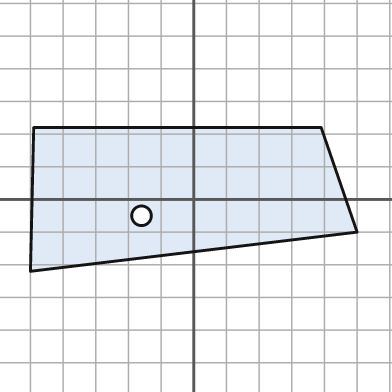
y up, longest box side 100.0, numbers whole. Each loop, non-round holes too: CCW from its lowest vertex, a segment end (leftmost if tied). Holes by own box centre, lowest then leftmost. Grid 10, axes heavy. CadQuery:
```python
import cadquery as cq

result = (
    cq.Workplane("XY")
    .moveTo(-50.0, -22.0)
    .lineTo(50.0, -10.0)
    .lineTo(39.0, 22.0)
    .lineTo(-49.0, 22.0)
    .close()
    .moveTo(-16.0, -5.0)
    .circle(3.0)
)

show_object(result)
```